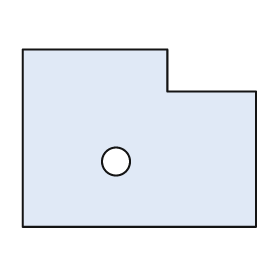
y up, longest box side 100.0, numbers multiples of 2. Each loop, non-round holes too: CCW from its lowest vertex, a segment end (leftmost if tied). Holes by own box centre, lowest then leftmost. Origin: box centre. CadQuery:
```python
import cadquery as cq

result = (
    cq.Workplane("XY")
    .moveTo(-50.0, -38.0)
    .lineTo(50.0, -38.0)
    .lineTo(50.0, 20.0)
    .lineTo(12.0, 20.0)
    .lineTo(12.0, 38.0)
    .lineTo(-50.0, 38.0)
    .close()
    .moveTo(-10.0, -10.0)
    .circle(6.0)
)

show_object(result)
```